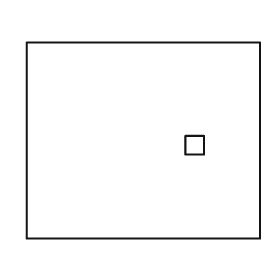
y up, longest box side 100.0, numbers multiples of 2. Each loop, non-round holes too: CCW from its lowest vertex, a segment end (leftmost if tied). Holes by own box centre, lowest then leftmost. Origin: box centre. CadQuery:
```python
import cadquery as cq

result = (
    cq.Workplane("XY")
    .moveTo(-50.0, -42.0)
    .lineTo(50.0, -42.0)
    .lineTo(50.0, 42.0)
    .lineTo(-50.0, 42.0)
    .close()
    .moveTo(18.0, -6.0)
    .lineTo(26.0, -6.0)
    .lineTo(26.0, 2.0)
    .lineTo(18.0, 2.0)
    .close()
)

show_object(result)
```